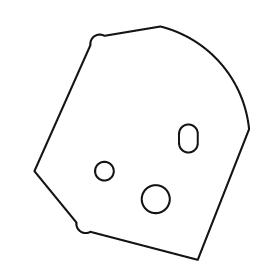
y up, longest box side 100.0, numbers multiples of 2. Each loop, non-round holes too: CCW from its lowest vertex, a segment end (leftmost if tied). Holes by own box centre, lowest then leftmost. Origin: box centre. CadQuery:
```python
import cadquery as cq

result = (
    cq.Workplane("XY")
    .moveTo(24.0, -50.0)
    .lineTo(46.0, 6.0)
    .threePointArc((34.0, 34.0), (8.0, 50.0))
    .lineTo(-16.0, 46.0)
    .threePointArc((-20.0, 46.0), (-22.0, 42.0))
    .lineTo(-46.0, -12.0)
    .lineTo(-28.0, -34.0)
    .threePointArc((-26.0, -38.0), (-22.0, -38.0))
    .close()
    .moveTo(6.0, -24.0)
    .circle(6.0)
    .moveTo(-16.0, -12.0)
    .circle(4.0)
    .moveTo(16.0, 0.0)
    .threePointArc((20.0, -4.0), (24.0, 0.0))
    .lineTo(24.0, 4.0)
    .threePointArc((20.0, 8.0), (16.0, 4.0))
    .close()
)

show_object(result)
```